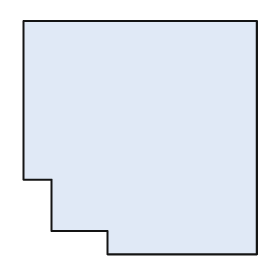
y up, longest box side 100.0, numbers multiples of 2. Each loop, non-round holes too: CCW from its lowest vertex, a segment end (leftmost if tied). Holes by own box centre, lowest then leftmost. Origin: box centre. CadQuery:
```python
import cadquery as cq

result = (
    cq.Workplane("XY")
    .moveTo(-14.0, -50.0)
    .lineTo(50.0, -50.0)
    .lineTo(50.0, 50.0)
    .lineTo(-50.0, 50.0)
    .lineTo(-50.0, -18.0)
    .lineTo(-38.0, -18.0)
    .lineTo(-38.0, -40.0)
    .lineTo(-14.0, -40.0)
    .close()
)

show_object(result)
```